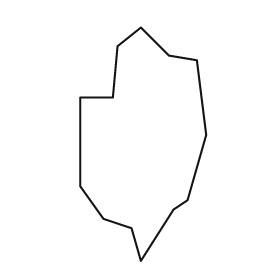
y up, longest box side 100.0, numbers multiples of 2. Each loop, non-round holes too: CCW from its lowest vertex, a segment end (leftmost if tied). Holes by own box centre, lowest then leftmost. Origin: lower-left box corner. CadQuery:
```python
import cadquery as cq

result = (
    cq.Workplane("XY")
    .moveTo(26.0, 0.0)
    .lineTo(40.0, 22.0)
    .lineTo(46.0, 26.0)
    .lineTo(54.0, 54.0)
    .lineTo(50.0, 86.0)
    .lineTo(38.0, 88.0)
    .lineTo(26.0, 100.0)
    .lineTo(16.0, 92.0)
    .lineTo(14.0, 70.0)
    .lineTo(0.0, 70.0)
    .lineTo(0.0, 32.0)
    .lineTo(10.0, 18.0)
    .lineTo(22.0, 14.0)
    .close()
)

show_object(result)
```